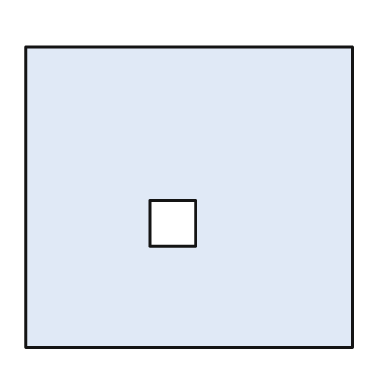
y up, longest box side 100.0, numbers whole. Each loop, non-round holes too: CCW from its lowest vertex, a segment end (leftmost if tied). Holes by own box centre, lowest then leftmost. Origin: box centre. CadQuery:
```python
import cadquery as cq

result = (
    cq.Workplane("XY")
    .moveTo(-50.0, -46.0)
    .lineTo(50.0, -46.0)
    .lineTo(50.0, 46.0)
    .lineTo(-50.0, 46.0)
    .close()
    .moveTo(-12.0, -15.0)
    .lineTo(2.0, -15.0)
    .lineTo(2.0, -1.0)
    .lineTo(-12.0, -1.0)
    .close()
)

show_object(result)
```